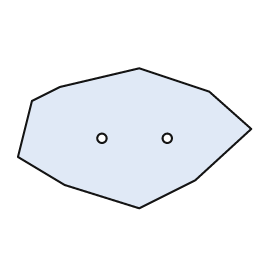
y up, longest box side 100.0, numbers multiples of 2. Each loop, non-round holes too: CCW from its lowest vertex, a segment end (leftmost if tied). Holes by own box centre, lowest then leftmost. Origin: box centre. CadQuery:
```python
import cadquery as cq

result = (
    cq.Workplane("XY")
    .moveTo(2.0, -30.0)
    .lineTo(26.0, -18.0)
    .lineTo(50.0, 4.0)
    .lineTo(32.0, 20.0)
    .lineTo(2.0, 30.0)
    .lineTo(-32.0, 22.0)
    .lineTo(-44.0, 16.0)
    .lineTo(-50.0, -8.0)
    .lineTo(-30.0, -20.0)
    .close()
    .moveTo(-14.0, 0.0)
    .circle(2.0)
    .moveTo(14.0, 0.0)
    .circle(2.0)
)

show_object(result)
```